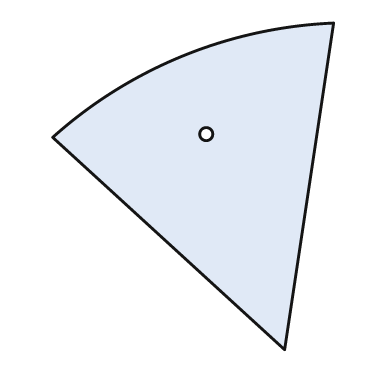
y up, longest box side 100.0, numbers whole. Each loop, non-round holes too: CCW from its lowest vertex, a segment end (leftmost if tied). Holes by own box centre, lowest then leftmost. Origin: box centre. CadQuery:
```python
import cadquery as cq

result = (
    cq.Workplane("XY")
    .moveTo(28.0, -50.0)
    .lineTo(43.0, 50.0)
    .threePointArc((-3.0, 40.0), (-43.0, 15.0))
    .close()
    .moveTo(4.0, 16.0)
    .circle(2.0)
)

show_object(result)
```